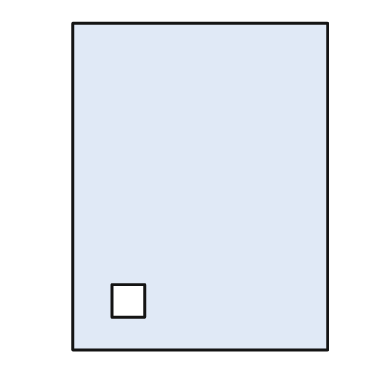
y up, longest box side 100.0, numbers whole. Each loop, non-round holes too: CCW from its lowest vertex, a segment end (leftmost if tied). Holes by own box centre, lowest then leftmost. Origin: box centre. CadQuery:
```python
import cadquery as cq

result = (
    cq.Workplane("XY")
    .moveTo(-39.0, -50.0)
    .lineTo(39.0, -50.0)
    .lineTo(39.0, 50.0)
    .lineTo(-39.0, 50.0)
    .close()
    .moveTo(-27.0, -40.0)
    .lineTo(-17.0, -40.0)
    .lineTo(-17.0, -30.0)
    .lineTo(-27.0, -30.0)
    .close()
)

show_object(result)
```